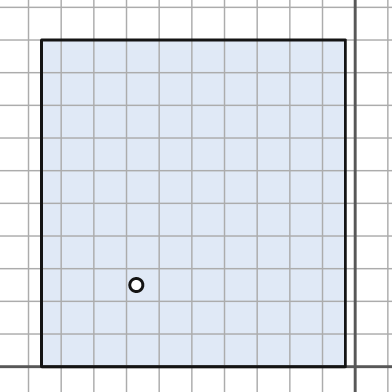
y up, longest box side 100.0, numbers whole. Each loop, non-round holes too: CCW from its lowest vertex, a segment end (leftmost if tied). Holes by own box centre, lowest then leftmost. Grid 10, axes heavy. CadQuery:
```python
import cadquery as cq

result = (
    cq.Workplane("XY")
    .moveTo(-96.0, 0.0)
    .lineTo(-3.0, 0.0)
    .lineTo(-3.0, 100.0)
    .lineTo(-96.0, 100.0)
    .close()
    .moveTo(-67.0, 25.0)
    .circle(2.0)
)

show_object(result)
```